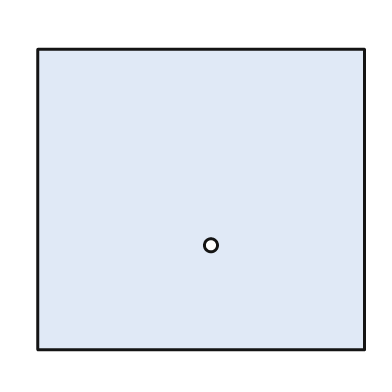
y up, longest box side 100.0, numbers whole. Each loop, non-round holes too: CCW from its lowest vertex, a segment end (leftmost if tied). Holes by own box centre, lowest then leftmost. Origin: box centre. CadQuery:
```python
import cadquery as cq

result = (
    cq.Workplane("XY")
    .moveTo(-50.0, -46.0)
    .lineTo(50.0, -46.0)
    .lineTo(50.0, 46.0)
    .lineTo(-50.0, 46.0)
    .close()
    .moveTo(3.0, -14.0)
    .circle(2.0)
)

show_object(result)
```